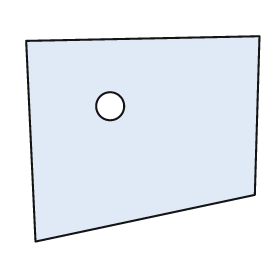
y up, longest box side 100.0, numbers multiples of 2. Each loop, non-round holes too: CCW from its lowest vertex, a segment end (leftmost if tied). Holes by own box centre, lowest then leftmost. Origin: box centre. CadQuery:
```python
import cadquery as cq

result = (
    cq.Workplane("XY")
    .moveTo(-46.0, -44.0)
    .lineTo(48.0, -24.0)
    .lineTo(50.0, 44.0)
    .lineTo(-50.0, 42.0)
    .close()
    .moveTo(-14.0, 14.0)
    .circle(6.0)
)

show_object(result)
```